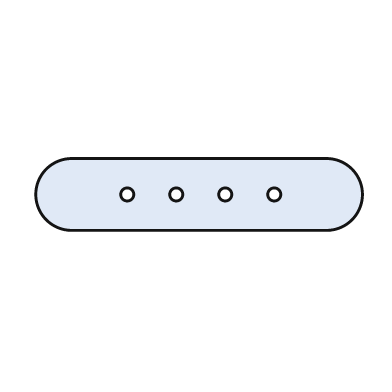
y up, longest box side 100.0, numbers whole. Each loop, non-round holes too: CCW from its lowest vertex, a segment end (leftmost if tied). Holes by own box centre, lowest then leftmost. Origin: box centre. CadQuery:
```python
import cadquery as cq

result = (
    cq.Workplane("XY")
    .moveTo(-39.0, -11.0)
    .lineTo(39.0, -11.0)
    .threePointArc((50.0, 0.0), (39.0, 11.0))
    .lineTo(-39.0, 11.0)
    .threePointArc((-50.0, 0.0), (-39.0, -11.0))
    .close()
    .moveTo(-22.0, 0.0)
    .circle(2.0)
    .moveTo(-7.0, 0.0)
    .circle(2.0)
    .moveTo(8.0, 0.0)
    .circle(2.0)
    .moveTo(23.0, 0.0)
    .circle(2.0)
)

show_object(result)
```